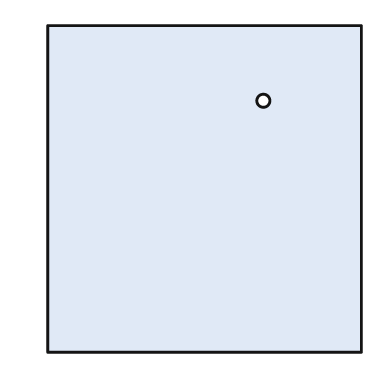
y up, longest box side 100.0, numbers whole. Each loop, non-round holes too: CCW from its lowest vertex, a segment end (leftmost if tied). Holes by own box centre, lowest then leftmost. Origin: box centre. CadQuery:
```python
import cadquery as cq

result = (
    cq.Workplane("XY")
    .moveTo(-48.0, -50.0)
    .lineTo(48.0, -50.0)
    .lineTo(48.0, 50.0)
    .lineTo(-48.0, 50.0)
    .close()
    .moveTo(18.0, 27.0)
    .circle(2.0)
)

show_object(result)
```